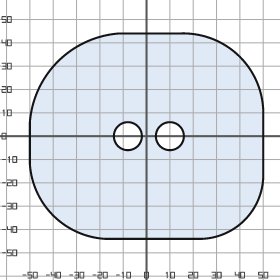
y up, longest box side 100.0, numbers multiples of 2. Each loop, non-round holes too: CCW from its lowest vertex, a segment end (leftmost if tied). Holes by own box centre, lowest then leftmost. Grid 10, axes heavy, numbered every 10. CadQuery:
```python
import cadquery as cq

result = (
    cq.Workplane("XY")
    .moveTo(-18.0, -44.0)
    .lineTo(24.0, -44.0)
    .threePointArc((42.0, -36.0), (50.0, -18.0))
    .lineTo(50.0, 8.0)
    .threePointArc((40.0, 34.0), (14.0, 44.0))
    .lineTo(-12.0, 44.0)
    .threePointArc((-38.0, 32.0), (-50.0, 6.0))
    .lineTo(-50.0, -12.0)
    .threePointArc((-40.0, -34.0), (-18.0, -44.0))
    .close()
    .moveTo(-8.0, 0.0)
    .circle(6.0)
    .moveTo(10.0, 0.0)
    .circle(6.0)
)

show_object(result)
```